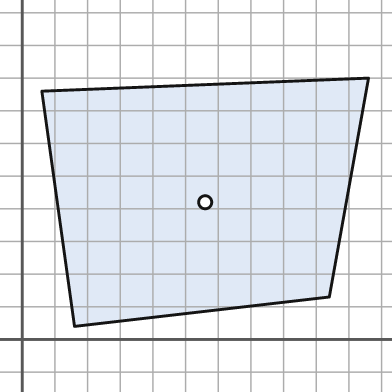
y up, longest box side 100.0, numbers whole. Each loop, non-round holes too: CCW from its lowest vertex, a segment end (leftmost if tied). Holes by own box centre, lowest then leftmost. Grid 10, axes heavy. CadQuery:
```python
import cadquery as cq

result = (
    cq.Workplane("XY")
    .moveTo(16.0, 4.0)
    .lineTo(94.0, 13.0)
    .lineTo(106.0, 80.0)
    .lineTo(6.0, 76.0)
    .close()
    .moveTo(56.0, 42.0)
    .circle(2.0)
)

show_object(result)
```